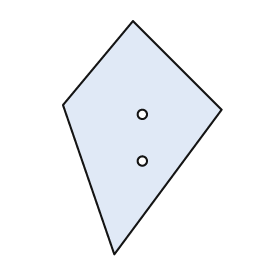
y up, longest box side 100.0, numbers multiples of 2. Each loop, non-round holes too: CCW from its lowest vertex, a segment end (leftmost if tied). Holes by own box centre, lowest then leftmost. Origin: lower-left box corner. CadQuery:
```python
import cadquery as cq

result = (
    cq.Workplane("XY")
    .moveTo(22.0, 0.0)
    .lineTo(68.0, 62.0)
    .lineTo(30.0, 100.0)
    .lineTo(0.0, 64.0)
    .close()
    .moveTo(34.0, 40.0)
    .circle(2.0)
    .moveTo(34.0, 60.0)
    .circle(2.0)
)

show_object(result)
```